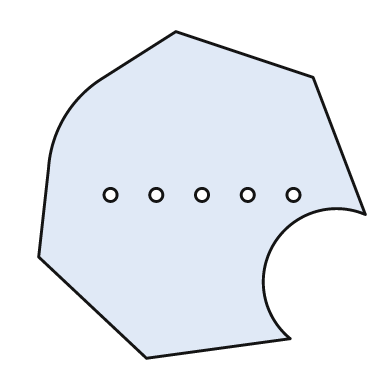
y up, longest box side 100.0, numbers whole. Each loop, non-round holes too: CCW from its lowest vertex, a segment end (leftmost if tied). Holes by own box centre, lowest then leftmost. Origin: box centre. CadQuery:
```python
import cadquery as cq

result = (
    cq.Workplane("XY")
    .moveTo(-17.0, -50.0)
    .lineTo(27.0, -44.0)
    .threePointArc((22.0, -15.0), (50.0, -6.0))
    .lineTo(34.0, 36.0)
    .lineTo(-8.0, 50.0)
    .lineTo(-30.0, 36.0)
    .threePointArc((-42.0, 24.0), (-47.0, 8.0))
    .lineTo(-50.0, -19.0)
    .close()
    .moveTo(-28.0, 0.0)
    .circle(2.0)
    .moveTo(-14.0, 0.0)
    .circle(2.0)
    .moveTo(0.0, 0.0)
    .circle(2.0)
    .moveTo(14.0, 0.0)
    .circle(2.0)
    .moveTo(28.0, 0.0)
    .circle(2.0)
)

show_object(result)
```